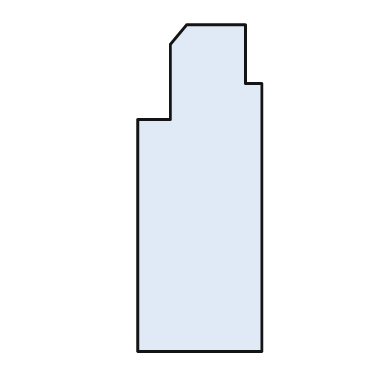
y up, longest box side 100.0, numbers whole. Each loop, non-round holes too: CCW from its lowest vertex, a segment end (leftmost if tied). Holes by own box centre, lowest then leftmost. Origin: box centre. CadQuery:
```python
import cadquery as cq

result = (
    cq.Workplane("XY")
    .moveTo(-19.0, -50.0)
    .lineTo(19.0, -50.0)
    .lineTo(19.0, 32.0)
    .lineTo(14.0, 32.0)
    .lineTo(14.0, 50.0)
    .lineTo(-4.0, 50.0)
    .lineTo(-9.0, 44.0)
    .lineTo(-9.0, 21.0)
    .lineTo(-19.0, 21.0)
    .close()
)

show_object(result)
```